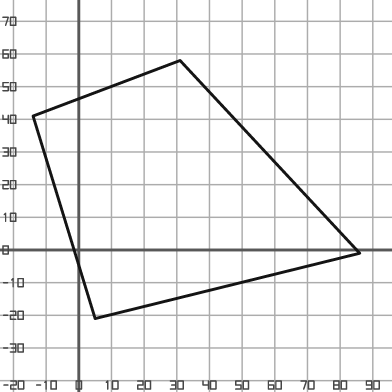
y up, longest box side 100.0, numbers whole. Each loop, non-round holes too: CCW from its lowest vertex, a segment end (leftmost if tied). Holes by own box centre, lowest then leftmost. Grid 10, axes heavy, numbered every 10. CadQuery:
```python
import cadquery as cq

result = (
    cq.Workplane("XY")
    .moveTo(5.0, -21.0)
    .lineTo(86.0, -1.0)
    .lineTo(31.0, 58.0)
    .lineTo(-14.0, 41.0)
    .close()
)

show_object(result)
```